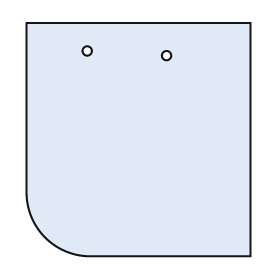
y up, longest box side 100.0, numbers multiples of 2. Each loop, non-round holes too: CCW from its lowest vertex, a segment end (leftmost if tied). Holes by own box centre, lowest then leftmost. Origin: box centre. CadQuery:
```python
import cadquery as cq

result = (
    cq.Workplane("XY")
    .moveTo(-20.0, -50.0)
    .lineTo(48.0, -50.0)
    .lineTo(48.0, 50.0)
    .lineTo(-48.0, 50.0)
    .lineTo(-48.0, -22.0)
    .threePointArc((-40.0, -42.0), (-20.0, -50.0))
    .close()
    .moveTo(12.0, 36.0)
    .circle(2.0)
    .moveTo(-22.0, 38.0)
    .circle(2.0)
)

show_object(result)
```